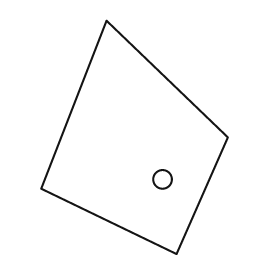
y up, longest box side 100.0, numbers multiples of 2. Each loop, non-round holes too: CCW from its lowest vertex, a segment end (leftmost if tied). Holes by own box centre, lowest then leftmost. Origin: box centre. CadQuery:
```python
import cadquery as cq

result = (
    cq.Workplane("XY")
    .moveTo(18.0, -50.0)
    .lineTo(40.0, 0.0)
    .lineTo(-12.0, 50.0)
    .lineTo(-40.0, -22.0)
    .close()
    .moveTo(12.0, -18.0)
    .circle(4.0)
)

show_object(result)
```